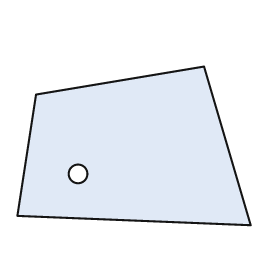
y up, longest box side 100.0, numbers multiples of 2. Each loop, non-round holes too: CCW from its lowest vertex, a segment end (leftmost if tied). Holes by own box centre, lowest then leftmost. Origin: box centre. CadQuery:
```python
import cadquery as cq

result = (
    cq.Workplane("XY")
    .moveTo(50.0, -34.0)
    .lineTo(30.0, 34.0)
    .lineTo(-42.0, 22.0)
    .lineTo(-50.0, -30.0)
    .close()
    .moveTo(-24.0, -12.0)
    .circle(4.0)
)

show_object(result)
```